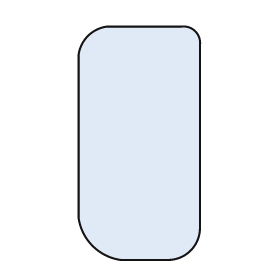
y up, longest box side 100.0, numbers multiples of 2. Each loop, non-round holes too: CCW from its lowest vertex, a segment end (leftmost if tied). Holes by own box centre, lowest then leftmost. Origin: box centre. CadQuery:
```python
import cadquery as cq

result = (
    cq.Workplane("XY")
    .moveTo(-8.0, -50.0)
    .lineTo(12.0, -50.0)
    .threePointArc((22.0, -46.0), (26.0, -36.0))
    .lineTo(26.0, 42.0)
    .threePointArc((24.0, 48.0), (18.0, 50.0))
    .lineTo(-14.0, 50.0)
    .threePointArc((-22.0, 46.0), (-26.0, 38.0))
    .lineTo(-26.0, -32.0)
    .threePointArc((-20.0, -44.0), (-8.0, -50.0))
    .close()
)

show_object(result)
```